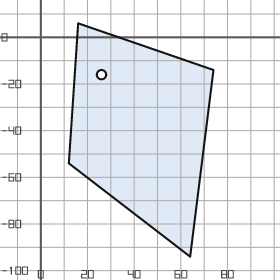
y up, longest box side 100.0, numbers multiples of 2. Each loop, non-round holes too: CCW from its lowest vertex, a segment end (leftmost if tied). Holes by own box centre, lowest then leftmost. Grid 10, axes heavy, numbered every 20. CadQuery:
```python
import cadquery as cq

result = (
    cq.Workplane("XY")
    .moveTo(64.0, -94.0)
    .lineTo(74.0, -14.0)
    .lineTo(16.0, 6.0)
    .lineTo(12.0, -54.0)
    .close()
    .moveTo(26.0, -16.0)
    .circle(2.0)
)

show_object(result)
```